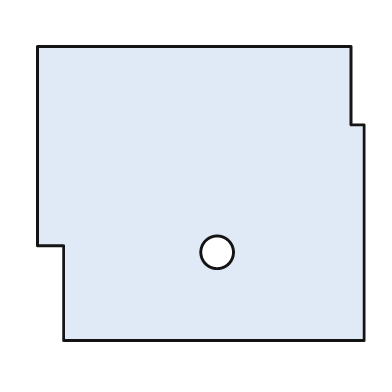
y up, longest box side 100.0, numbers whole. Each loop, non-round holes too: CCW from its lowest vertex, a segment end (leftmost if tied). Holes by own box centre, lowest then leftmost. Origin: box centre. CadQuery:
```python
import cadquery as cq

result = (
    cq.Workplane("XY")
    .moveTo(-42.0, -45.0)
    .lineTo(50.0, -45.0)
    .lineTo(50.0, 21.0)
    .lineTo(46.0, 21.0)
    .lineTo(46.0, 45.0)
    .lineTo(-50.0, 45.0)
    .lineTo(-50.0, -16.0)
    .lineTo(-42.0, -16.0)
    .close()
    .moveTo(5.0, -18.0)
    .circle(5.0)
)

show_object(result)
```